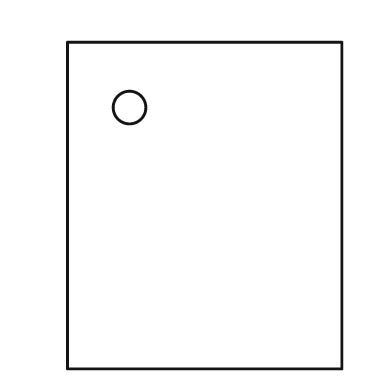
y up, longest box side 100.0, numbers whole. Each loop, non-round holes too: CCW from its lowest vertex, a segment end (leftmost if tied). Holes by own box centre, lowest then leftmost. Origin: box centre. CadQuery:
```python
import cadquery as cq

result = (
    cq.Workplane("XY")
    .moveTo(-42.0, -50.0)
    .lineTo(42.0, -50.0)
    .lineTo(42.0, 50.0)
    .lineTo(-42.0, 50.0)
    .close()
    .moveTo(-23.0, 30.0)
    .circle(5.0)
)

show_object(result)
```